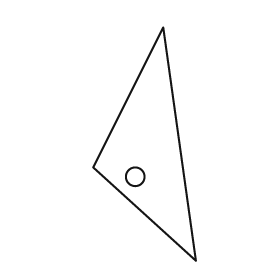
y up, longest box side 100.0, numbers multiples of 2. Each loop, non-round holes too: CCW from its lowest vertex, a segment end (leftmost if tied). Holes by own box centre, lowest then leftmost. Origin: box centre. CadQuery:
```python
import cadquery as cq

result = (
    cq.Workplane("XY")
    .moveTo(22.0, -50.0)
    .lineTo(8.0, 50.0)
    .lineTo(-22.0, -10.0)
    .close()
    .moveTo(-4.0, -14.0)
    .circle(4.0)
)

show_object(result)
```